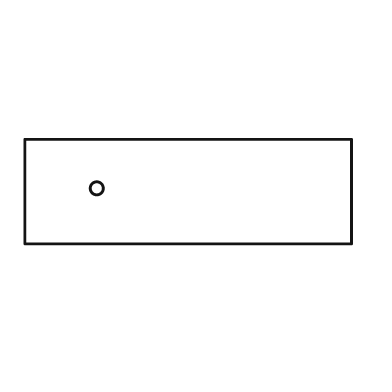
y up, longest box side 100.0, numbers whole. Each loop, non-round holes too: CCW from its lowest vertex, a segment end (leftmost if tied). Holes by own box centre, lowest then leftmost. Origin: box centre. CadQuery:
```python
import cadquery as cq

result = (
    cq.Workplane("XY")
    .moveTo(-50.0, -16.0)
    .lineTo(50.0, -16.0)
    .lineTo(50.0, 16.0)
    .lineTo(-50.0, 16.0)
    .close()
    .moveTo(-28.0, 1.0)
    .circle(2.0)
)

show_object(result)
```